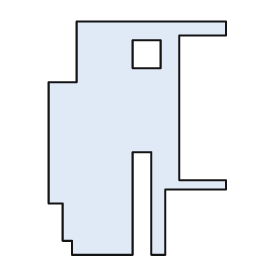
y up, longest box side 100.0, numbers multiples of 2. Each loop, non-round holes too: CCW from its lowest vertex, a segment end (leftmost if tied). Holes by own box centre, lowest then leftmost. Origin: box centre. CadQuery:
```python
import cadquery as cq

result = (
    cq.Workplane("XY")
    .moveTo(-28.0, -50.0)
    .lineTo(-2.0, -50.0)
    .lineTo(-2.0, -6.0)
    .lineTo(6.0, -6.0)
    .lineTo(6.0, -50.0)
    .lineTo(12.0, -50.0)
    .lineTo(12.0, -22.0)
    .lineTo(38.0, -22.0)
    .lineTo(38.0, -18.0)
    .lineTo(18.0, -18.0)
    .lineTo(18.0, 44.0)
    .lineTo(38.0, 44.0)
    .lineTo(38.0, 50.0)
    .lineTo(-26.0, 50.0)
    .lineTo(-26.0, 24.0)
    .lineTo(-38.0, 24.0)
    .lineTo(-38.0, -28.0)
    .lineTo(-32.0, -28.0)
    .lineTo(-32.0, -44.0)
    .lineTo(-28.0, -44.0)
    .close()
    .moveTo(-2.0, 30.0)
    .lineTo(10.0, 30.0)
    .lineTo(10.0, 42.0)
    .lineTo(-2.0, 42.0)
    .close()
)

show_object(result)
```